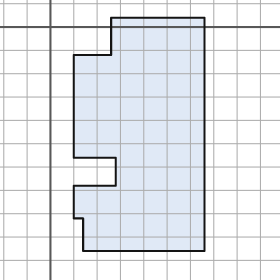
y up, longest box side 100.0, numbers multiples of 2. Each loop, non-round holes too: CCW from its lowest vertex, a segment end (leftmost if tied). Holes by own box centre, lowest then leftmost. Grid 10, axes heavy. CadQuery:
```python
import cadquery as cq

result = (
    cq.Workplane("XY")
    .moveTo(14.0, -96.0)
    .lineTo(66.0, -96.0)
    .lineTo(66.0, 4.0)
    .lineTo(26.0, 4.0)
    .lineTo(26.0, -12.0)
    .lineTo(10.0, -12.0)
    .lineTo(10.0, -56.0)
    .lineTo(28.0, -56.0)
    .lineTo(28.0, -68.0)
    .lineTo(10.0, -68.0)
    .lineTo(10.0, -82.0)
    .lineTo(14.0, -82.0)
    .close()
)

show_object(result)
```